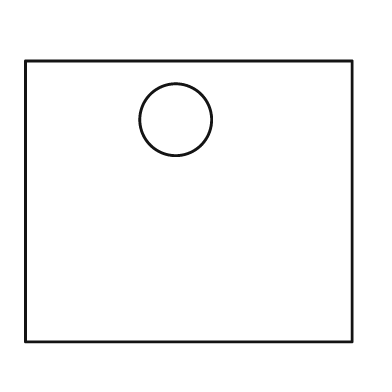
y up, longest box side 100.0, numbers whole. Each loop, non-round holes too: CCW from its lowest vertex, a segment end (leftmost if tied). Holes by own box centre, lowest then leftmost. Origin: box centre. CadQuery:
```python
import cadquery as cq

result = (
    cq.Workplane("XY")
    .moveTo(-50.0, -43.0)
    .lineTo(50.0, -43.0)
    .lineTo(50.0, 43.0)
    .lineTo(-50.0, 43.0)
    .close()
    .moveTo(-4.0, 25.0)
    .circle(11.0)
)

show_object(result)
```